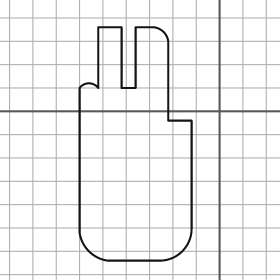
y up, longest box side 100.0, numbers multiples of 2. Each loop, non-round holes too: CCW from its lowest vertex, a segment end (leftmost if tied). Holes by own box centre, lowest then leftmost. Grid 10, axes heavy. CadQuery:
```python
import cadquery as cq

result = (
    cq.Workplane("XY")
    .moveTo(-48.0, -64.0)
    .lineTo(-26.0, -64.0)
    .threePointArc((-16.0, -60.0), (-12.0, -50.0))
    .lineTo(-12.0, -4.0)
    .lineTo(-22.0, -4.0)
    .lineTo(-22.0, 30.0)
    .threePointArc((-24.0, 34.0), (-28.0, 36.0))
    .lineTo(-36.0, 36.0)
    .lineTo(-36.0, 10.0)
    .lineTo(-42.0, 10.0)
    .lineTo(-42.0, 36.0)
    .lineTo(-52.0, 36.0)
    .lineTo(-52.0, 10.0)
    .threePointArc((-56.0, 12.0), (-60.0, 10.0))
    .lineTo(-60.0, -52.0)
    .threePointArc((-56.0, -60.0), (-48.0, -64.0))
    .close()
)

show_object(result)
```